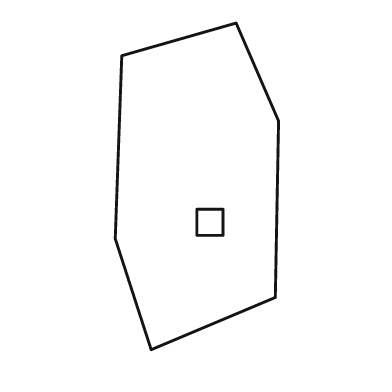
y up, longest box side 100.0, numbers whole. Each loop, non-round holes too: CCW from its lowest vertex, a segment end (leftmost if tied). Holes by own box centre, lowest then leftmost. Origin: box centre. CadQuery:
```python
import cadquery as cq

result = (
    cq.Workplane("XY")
    .moveTo(-14.0, -50.0)
    .lineTo(24.0, -34.0)
    .lineTo(25.0, 20.0)
    .lineTo(12.0, 50.0)
    .lineTo(-23.0, 40.0)
    .lineTo(-25.0, -16.0)
    .close()
    .moveTo(0.0, -15.0)
    .lineTo(8.0, -15.0)
    .lineTo(8.0, -7.0)
    .lineTo(0.0, -7.0)
    .close()
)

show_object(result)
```